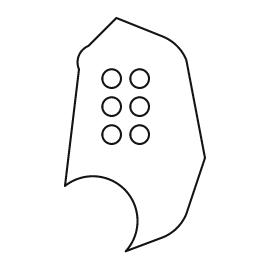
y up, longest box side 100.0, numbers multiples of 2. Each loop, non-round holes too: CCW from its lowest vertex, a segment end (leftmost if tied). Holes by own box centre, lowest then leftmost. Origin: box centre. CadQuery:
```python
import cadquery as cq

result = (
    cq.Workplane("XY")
    .moveTo(-4.0, -50.0)
    .lineTo(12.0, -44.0)
    .threePointArc((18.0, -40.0), (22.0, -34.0))
    .lineTo(30.0, -10.0)
    .lineTo(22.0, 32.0)
    .threePointArc((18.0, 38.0), (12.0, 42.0))
    .lineTo(-8.0, 50.0)
    .lineTo(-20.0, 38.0)
    .threePointArc((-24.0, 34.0), (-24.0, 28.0))
    .lineTo(-30.0, -22.0)
    .threePointArc((-4.0, -24.0), (-4.0, -50.0))
    .close()
    .moveTo(-10.0, 0.0)
    .circle(4.0)
    .moveTo(2.0, 0.0)
    .circle(4.0)
    .moveTo(-10.0, 12.0)
    .circle(4.0)
    .moveTo(2.0, 12.0)
    .circle(4.0)
    .moveTo(-10.0, 24.0)
    .circle(4.0)
    .moveTo(2.0, 24.0)
    .circle(4.0)
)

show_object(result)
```